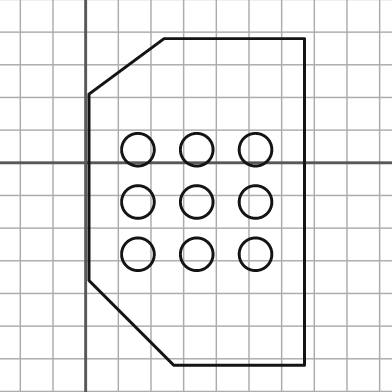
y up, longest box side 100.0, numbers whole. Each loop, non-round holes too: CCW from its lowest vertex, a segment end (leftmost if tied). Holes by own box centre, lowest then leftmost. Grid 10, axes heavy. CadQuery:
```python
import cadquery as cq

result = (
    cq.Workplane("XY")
    .moveTo(27.0, -62.0)
    .lineTo(67.0, -62.0)
    .lineTo(67.0, 38.0)
    .lineTo(24.0, 38.0)
    .lineTo(1.0, 21.0)
    .lineTo(1.0, -36.0)
    .close()
    .moveTo(16.0, -28.0)
    .circle(5.0)
    .moveTo(34.0, -28.0)
    .circle(5.0)
    .moveTo(52.0, -28.0)
    .circle(5.0)
    .moveTo(16.0, -12.0)
    .circle(5.0)
    .moveTo(34.0, -12.0)
    .circle(5.0)
    .moveTo(52.0, -12.0)
    .circle(5.0)
    .moveTo(16.0, 4.0)
    .circle(5.0)
    .moveTo(34.0, 4.0)
    .circle(5.0)
    .moveTo(52.0, 4.0)
    .circle(5.0)
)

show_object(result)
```